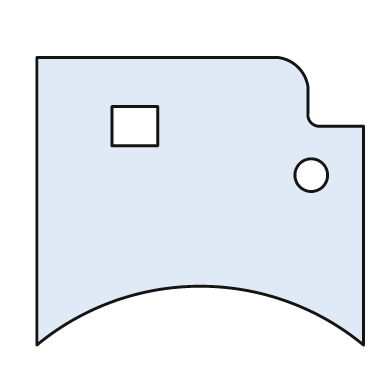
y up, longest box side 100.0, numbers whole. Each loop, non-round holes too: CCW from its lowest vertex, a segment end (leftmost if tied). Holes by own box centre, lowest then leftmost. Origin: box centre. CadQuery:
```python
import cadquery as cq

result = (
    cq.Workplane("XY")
    .moveTo(-50.0, -44.0)
    .threePointArc((0.0, -26.0), (50.0, -44.0))
    .lineTo(50.0, 23.0)
    .lineTo(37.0, 23.0)
    .threePointArc((34.0, 24.0), (33.0, 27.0))
    .lineTo(33.0, 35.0)
    .threePointArc((30.0, 41.0), (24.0, 44.0))
    .lineTo(-50.0, 44.0)
    .close()
    .moveTo(34.0, 8.0)
    .circle(5.0)
    .moveTo(-27.0, 17.0)
    .lineTo(-13.0, 17.0)
    .lineTo(-13.0, 29.0)
    .lineTo(-27.0, 29.0)
    .close()
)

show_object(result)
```